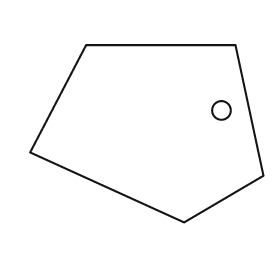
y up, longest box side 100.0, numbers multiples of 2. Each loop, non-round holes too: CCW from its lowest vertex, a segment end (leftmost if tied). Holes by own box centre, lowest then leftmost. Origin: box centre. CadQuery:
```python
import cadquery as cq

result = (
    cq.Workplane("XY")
    .moveTo(16.0, -38.0)
    .lineTo(50.0, -18.0)
    .lineTo(38.0, 38.0)
    .lineTo(-26.0, 38.0)
    .lineTo(-50.0, -8.0)
    .close()
    .moveTo(32.0, 10.0)
    .circle(4.0)
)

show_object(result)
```